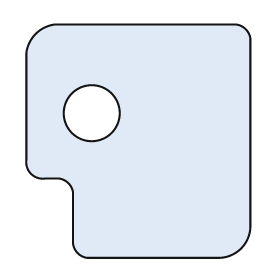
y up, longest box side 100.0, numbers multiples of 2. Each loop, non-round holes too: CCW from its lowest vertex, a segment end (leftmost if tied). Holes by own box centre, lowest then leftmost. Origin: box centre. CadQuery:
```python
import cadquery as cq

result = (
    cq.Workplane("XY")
    .moveTo(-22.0, -50.0)
    .lineTo(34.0, -50.0)
    .threePointArc((44.0, -46.0), (48.0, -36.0))
    .lineTo(48.0, 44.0)
    .threePointArc((46.0, 48.0), (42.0, 50.0))
    .lineTo(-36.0, 50.0)
    .threePointArc((-44.0, 46.0), (-48.0, 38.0))
    .lineTo(-48.0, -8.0)
    .threePointArc((-46.0, -14.0), (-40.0, -16.0))
    .lineTo(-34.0, -16.0)
    .threePointArc((-30.0, -18.0), (-28.0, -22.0))
    .lineTo(-28.0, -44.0)
    .threePointArc((-26.0, -48.0), (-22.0, -50.0))
    .close()
    .moveTo(-20.0, 12.0)
    .circle(12.0)
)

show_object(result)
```